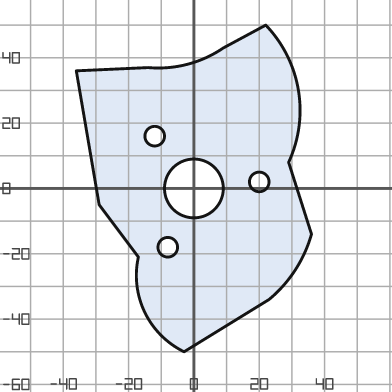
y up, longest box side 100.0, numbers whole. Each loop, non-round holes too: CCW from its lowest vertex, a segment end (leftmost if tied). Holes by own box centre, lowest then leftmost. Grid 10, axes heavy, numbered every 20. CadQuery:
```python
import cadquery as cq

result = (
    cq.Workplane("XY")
    .moveTo(-3.0, -50.0)
    .lineTo(23.0, -34.0)
    .threePointArc((31.0, -25.0), (36.0, -14.0))
    .lineTo(29.0, 8.0)
    .threePointArc((32.0, 30.0), (22.0, 50.0))
    .lineTo(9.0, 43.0)
    .threePointArc((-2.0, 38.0), (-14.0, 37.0))
    .lineTo(-36.0, 36.0)
    .lineTo(-29.0, -5.0)
    .lineTo(-17.0, -21.0)
    .threePointArc((-15.0, -38.0), (-3.0, -50.0))
    .close()
    .moveTo(-8.0, -18.0)
    .circle(3.0)
    .moveTo(0.0, 0.0)
    .circle(9.0)
    .moveTo(20.0, 2.0)
    .circle(3.0)
    .moveTo(-12.0, 16.0)
    .circle(3.0)
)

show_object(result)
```